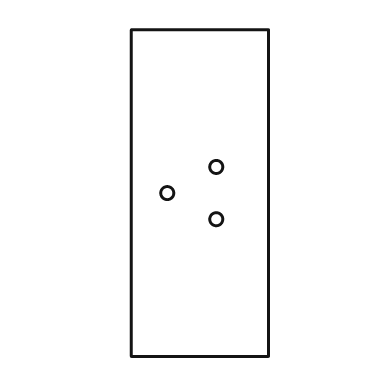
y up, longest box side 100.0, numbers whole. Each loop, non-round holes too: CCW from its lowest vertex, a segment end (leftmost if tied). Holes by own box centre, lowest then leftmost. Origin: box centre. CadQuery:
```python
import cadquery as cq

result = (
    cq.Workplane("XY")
    .moveTo(-21.0, -50.0)
    .lineTo(21.0, -50.0)
    .lineTo(21.0, 50.0)
    .lineTo(-21.0, 50.0)
    .close()
    .moveTo(5.0, -8.0)
    .circle(2.0)
    .moveTo(-10.0, 0.0)
    .circle(2.0)
    .moveTo(5.0, 8.0)
    .circle(2.0)
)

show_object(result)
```